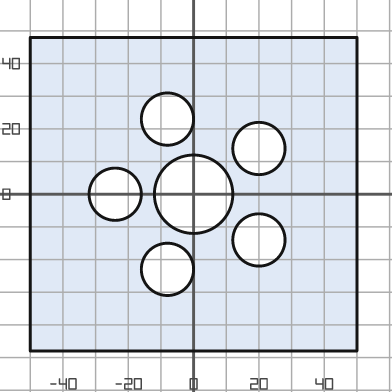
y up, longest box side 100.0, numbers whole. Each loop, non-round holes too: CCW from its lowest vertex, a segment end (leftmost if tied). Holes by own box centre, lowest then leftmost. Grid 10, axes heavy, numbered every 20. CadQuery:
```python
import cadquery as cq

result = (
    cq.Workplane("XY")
    .moveTo(-50.0, -48.0)
    .lineTo(50.0, -48.0)
    .lineTo(50.0, 48.0)
    .lineTo(-50.0, 48.0)
    .close()
    .moveTo(-8.0, -23.0)
    .circle(8.0)
    .moveTo(20.0, -14.0)
    .circle(8.0)
    .moveTo(-24.0, 0.0)
    .circle(8.0)
    .moveTo(0.0, 0.0)
    .circle(12.0)
    .moveTo(20.0, 14.0)
    .circle(8.0)
    .moveTo(-8.0, 23.0)
    .circle(8.0)
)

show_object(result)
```